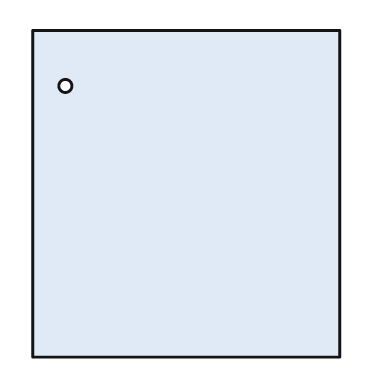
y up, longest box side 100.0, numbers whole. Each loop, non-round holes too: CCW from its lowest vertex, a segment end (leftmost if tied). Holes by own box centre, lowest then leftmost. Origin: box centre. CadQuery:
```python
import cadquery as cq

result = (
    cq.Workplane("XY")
    .moveTo(-47.0, -50.0)
    .lineTo(47.0, -50.0)
    .lineTo(47.0, 50.0)
    .lineTo(-47.0, 50.0)
    .close()
    .moveTo(-37.0, 33.0)
    .circle(2.0)
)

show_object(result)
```